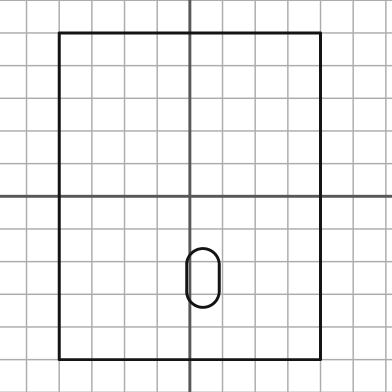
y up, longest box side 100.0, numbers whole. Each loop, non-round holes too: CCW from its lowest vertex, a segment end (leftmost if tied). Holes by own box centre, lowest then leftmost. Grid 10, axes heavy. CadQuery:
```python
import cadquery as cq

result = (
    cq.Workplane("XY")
    .moveTo(-40.0, -50.0)
    .lineTo(40.0, -50.0)
    .lineTo(40.0, 50.0)
    .lineTo(-40.0, 50.0)
    .close()
    .moveTo(-1.0, -29.0)
    .threePointArc((4.0, -34.0), (9.0, -29.0))
    .lineTo(9.0, -21.0)
    .threePointArc((4.0, -16.0), (-1.0, -21.0))
    .close()
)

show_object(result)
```